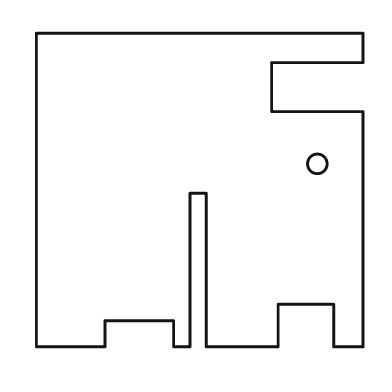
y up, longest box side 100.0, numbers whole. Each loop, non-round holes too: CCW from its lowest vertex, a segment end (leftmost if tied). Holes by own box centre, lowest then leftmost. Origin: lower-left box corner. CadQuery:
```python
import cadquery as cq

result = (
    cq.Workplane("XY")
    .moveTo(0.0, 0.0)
    .lineTo(21.0, 0.0)
    .lineTo(21.0, 8.0)
    .lineTo(42.0, 8.0)
    .lineTo(42.0, 0.0)
    .lineTo(47.0, 0.0)
    .lineTo(47.0, 47.0)
    .lineTo(52.0, 47.0)
    .lineTo(52.0, 0.0)
    .lineTo(74.0, 0.0)
    .lineTo(74.0, 13.0)
    .lineTo(91.0, 13.0)
    .lineTo(91.0, 0.0)
    .lineTo(100.0, 0.0)
    .lineTo(100.0, 72.0)
    .lineTo(72.0, 72.0)
    .lineTo(72.0, 87.0)
    .lineTo(100.0, 87.0)
    .lineTo(100.0, 96.0)
    .lineTo(0.0, 96.0)
    .close()
    .moveTo(86.0, 56.0)
    .circle(3.0)
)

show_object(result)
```